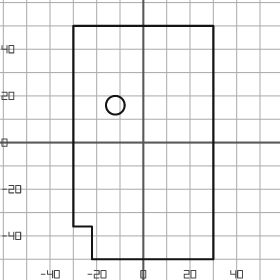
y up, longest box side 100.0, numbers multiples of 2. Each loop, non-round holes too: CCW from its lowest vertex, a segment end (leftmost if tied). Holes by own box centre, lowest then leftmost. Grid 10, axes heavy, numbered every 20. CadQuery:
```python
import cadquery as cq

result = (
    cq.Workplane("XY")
    .moveTo(-22.0, -50.0)
    .lineTo(30.0, -50.0)
    .lineTo(30.0, 50.0)
    .lineTo(-30.0, 50.0)
    .lineTo(-30.0, -36.0)
    .lineTo(-22.0, -36.0)
    .close()
    .moveTo(-12.0, 16.0)
    .circle(4.0)
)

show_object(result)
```